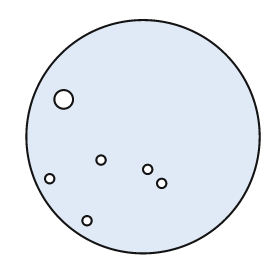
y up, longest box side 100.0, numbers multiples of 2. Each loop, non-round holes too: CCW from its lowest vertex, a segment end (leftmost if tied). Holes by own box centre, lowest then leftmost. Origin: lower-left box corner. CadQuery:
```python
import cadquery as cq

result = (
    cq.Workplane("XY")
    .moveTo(50.0, 50.0)
    .circle(50.0)
    .moveTo(26.0, 14.0)
    .circle(2.0)
    .moveTo(58.0, 30.0)
    .circle(2.0)
    .moveTo(10.0, 32.0)
    .circle(2.0)
    .moveTo(52.0, 36.0)
    .circle(2.0)
    .moveTo(32.0, 40.0)
    .circle(2.0)
    .moveTo(16.0, 66.0)
    .circle(4.0)
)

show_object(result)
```